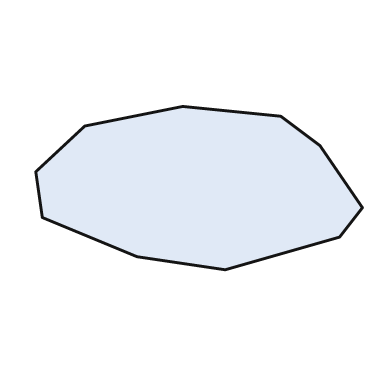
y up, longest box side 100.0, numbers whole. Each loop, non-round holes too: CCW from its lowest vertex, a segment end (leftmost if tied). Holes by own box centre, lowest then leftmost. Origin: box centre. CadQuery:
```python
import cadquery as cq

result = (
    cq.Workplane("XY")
    .moveTo(8.0, -25.0)
    .lineTo(43.0, -15.0)
    .lineTo(50.0, -6.0)
    .lineTo(37.0, 13.0)
    .lineTo(25.0, 22.0)
    .lineTo(-5.0, 25.0)
    .lineTo(-35.0, 19.0)
    .lineTo(-50.0, 5.0)
    .lineTo(-48.0, -9.0)
    .lineTo(-19.0, -21.0)
    .close()
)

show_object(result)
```